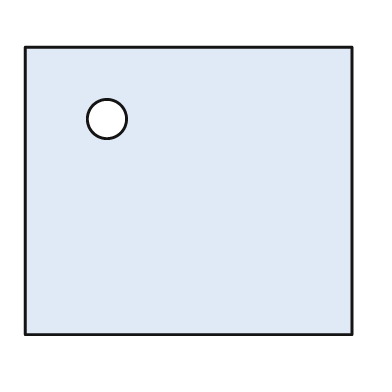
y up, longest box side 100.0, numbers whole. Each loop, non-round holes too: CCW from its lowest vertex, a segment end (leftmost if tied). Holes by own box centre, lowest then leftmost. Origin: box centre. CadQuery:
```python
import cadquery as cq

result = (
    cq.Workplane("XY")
    .moveTo(-50.0, -44.0)
    .lineTo(50.0, -44.0)
    .lineTo(50.0, 44.0)
    .lineTo(-50.0, 44.0)
    .close()
    .moveTo(-25.0, 22.0)
    .circle(6.0)
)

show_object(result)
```